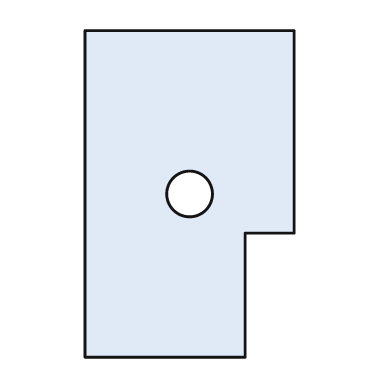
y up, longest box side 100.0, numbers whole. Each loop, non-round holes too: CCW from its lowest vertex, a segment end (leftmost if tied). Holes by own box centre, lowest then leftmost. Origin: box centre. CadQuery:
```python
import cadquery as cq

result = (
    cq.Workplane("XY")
    .moveTo(-32.0, -50.0)
    .lineTo(17.0, -50.0)
    .lineTo(17.0, -12.0)
    .lineTo(32.0, -12.0)
    .lineTo(32.0, 50.0)
    .lineTo(-32.0, 50.0)
    .close()
    .moveTo(0.0, 0.0)
    .circle(7.0)
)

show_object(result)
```